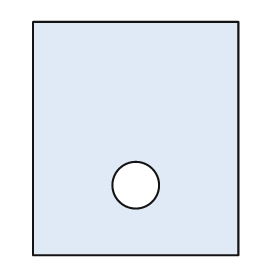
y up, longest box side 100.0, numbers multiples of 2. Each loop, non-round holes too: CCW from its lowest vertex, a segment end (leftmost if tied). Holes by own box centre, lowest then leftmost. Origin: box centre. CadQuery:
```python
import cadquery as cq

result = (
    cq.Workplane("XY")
    .moveTo(-44.0, -50.0)
    .lineTo(44.0, -50.0)
    .lineTo(44.0, 50.0)
    .lineTo(-44.0, 50.0)
    .close()
    .moveTo(0.0, -20.0)
    .circle(10.0)
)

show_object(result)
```